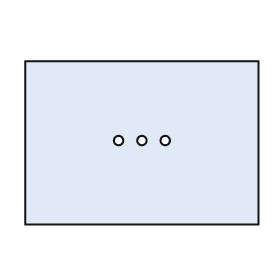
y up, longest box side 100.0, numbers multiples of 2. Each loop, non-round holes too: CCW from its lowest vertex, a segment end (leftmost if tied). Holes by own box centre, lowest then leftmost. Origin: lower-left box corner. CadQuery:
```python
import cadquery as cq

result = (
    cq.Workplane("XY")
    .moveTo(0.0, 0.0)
    .lineTo(100.0, 0.0)
    .lineTo(100.0, 70.0)
    .lineTo(0.0, 70.0)
    .close()
    .moveTo(40.0, 36.0)
    .circle(2.0)
    .moveTo(50.0, 36.0)
    .circle(2.0)
    .moveTo(60.0, 36.0)
    .circle(2.0)
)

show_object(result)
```